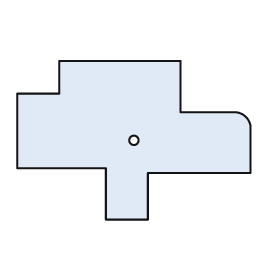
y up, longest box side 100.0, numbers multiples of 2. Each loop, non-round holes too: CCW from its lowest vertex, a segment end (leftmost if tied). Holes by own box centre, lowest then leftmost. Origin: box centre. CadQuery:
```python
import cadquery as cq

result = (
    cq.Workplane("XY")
    .moveTo(-12.0, -34.0)
    .lineTo(6.0, -34.0)
    .lineTo(6.0, -14.0)
    .lineTo(50.0, -14.0)
    .lineTo(50.0, 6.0)
    .threePointArc((48.0, 10.0), (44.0, 12.0))
    .lineTo(20.0, 12.0)
    .lineTo(20.0, 34.0)
    .lineTo(-32.0, 34.0)
    .lineTo(-32.0, 20.0)
    .lineTo(-50.0, 20.0)
    .lineTo(-50.0, -12.0)
    .lineTo(-12.0, -12.0)
    .close()
    .moveTo(0.0, 0.0)
    .circle(2.0)
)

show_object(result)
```